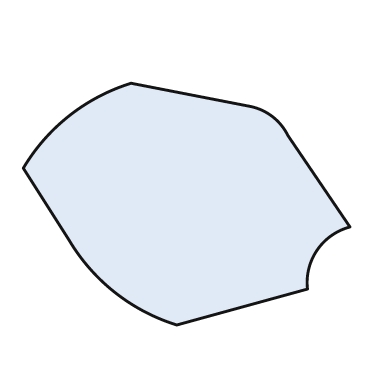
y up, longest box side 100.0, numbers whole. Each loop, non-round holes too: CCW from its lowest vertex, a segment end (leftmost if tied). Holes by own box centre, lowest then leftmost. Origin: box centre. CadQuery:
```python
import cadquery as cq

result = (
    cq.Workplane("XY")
    .moveTo(-3.0, -37.0)
    .lineTo(37.0, -26.0)
    .threePointArc((40.0, -14.0), (50.0, -7.0))
    .lineTo(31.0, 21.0)
    .threePointArc((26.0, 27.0), (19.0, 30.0))
    .lineTo(-17.0, 37.0)
    .threePointArc((-36.0, 27.0), (-50.0, 11.0))
    .lineTo(-36.0, -11.0)
    .threePointArc((-22.0, -27.0), (-3.0, -37.0))
    .close()
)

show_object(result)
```